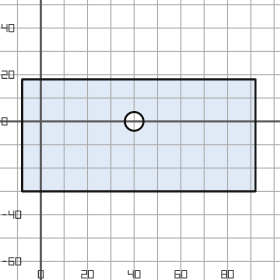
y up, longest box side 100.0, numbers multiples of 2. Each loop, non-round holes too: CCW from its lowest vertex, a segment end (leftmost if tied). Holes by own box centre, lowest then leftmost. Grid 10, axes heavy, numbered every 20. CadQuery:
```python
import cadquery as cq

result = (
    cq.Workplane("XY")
    .moveTo(-8.0, -30.0)
    .lineTo(92.0, -30.0)
    .lineTo(92.0, 18.0)
    .lineTo(-8.0, 18.0)
    .close()
    .moveTo(40.0, 0.0)
    .circle(4.0)
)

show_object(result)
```